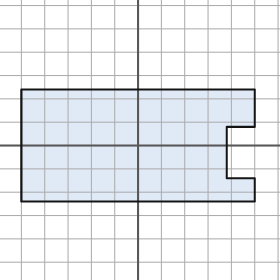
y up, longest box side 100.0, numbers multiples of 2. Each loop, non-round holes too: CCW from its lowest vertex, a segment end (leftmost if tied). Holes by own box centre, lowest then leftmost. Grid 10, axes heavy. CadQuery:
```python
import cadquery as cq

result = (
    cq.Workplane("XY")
    .moveTo(-50.0, -24.0)
    .lineTo(50.0, -24.0)
    .lineTo(50.0, -14.0)
    .lineTo(38.0, -14.0)
    .lineTo(38.0, 8.0)
    .lineTo(50.0, 8.0)
    .lineTo(50.0, 24.0)
    .lineTo(-50.0, 24.0)
    .close()
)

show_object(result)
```